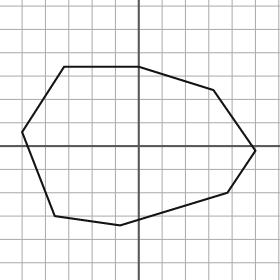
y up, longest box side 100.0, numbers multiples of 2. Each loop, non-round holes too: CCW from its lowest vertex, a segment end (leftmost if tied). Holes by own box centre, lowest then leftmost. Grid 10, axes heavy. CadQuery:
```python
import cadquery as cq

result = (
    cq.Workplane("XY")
    .moveTo(-8.0, -34.0)
    .lineTo(38.0, -20.0)
    .lineTo(50.0, -2.0)
    .lineTo(32.0, 24.0)
    .lineTo(0.0, 34.0)
    .lineTo(-32.0, 34.0)
    .lineTo(-50.0, 6.0)
    .lineTo(-36.0, -30.0)
    .close()
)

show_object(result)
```